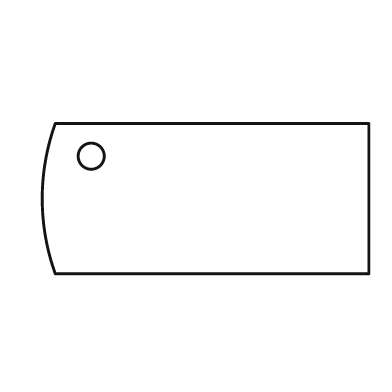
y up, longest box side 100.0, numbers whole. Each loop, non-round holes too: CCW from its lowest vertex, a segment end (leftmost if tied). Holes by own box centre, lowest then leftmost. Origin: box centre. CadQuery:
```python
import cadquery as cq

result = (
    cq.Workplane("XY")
    .moveTo(-46.0, -23.0)
    .lineTo(50.0, -23.0)
    .lineTo(50.0, 23.0)
    .lineTo(-46.0, 23.0)
    .threePointArc((-50.0, 0.0), (-46.0, -23.0))
    .close()
    .moveTo(-35.0, 13.0)
    .circle(4.0)
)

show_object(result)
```